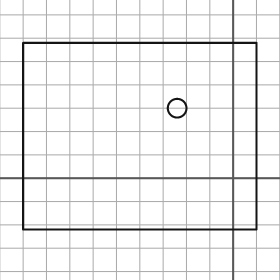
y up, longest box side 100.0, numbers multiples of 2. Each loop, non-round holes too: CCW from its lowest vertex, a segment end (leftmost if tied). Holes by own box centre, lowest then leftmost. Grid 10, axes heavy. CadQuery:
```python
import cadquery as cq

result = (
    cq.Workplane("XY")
    .moveTo(-90.0, -22.0)
    .lineTo(10.0, -22.0)
    .lineTo(10.0, 58.0)
    .lineTo(-90.0, 58.0)
    .close()
    .moveTo(-24.0, 30.0)
    .circle(4.0)
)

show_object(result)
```